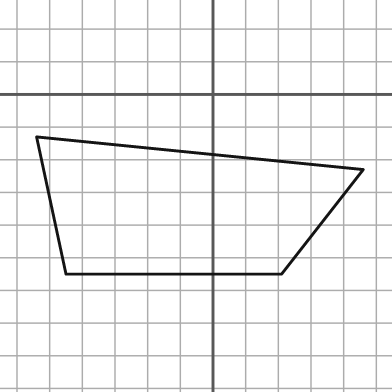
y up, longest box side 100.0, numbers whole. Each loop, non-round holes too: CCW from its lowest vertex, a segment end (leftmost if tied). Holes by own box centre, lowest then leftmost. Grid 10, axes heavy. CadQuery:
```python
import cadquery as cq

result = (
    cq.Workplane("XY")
    .moveTo(-45.0, -55.0)
    .lineTo(21.0, -55.0)
    .lineTo(46.0, -23.0)
    .lineTo(-54.0, -13.0)
    .close()
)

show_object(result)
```